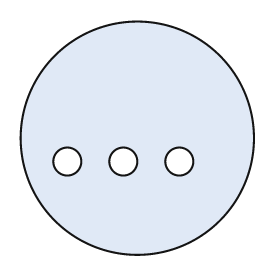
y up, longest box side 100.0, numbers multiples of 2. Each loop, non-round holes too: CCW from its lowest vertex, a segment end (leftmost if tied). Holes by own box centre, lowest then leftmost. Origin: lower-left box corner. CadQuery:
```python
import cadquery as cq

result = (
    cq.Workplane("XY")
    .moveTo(50.0, 50.0)
    .circle(50.0)
    .moveTo(20.0, 40.0)
    .circle(6.0)
    .moveTo(44.0, 40.0)
    .circle(6.0)
    .moveTo(68.0, 40.0)
    .circle(6.0)
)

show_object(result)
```